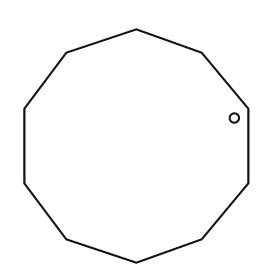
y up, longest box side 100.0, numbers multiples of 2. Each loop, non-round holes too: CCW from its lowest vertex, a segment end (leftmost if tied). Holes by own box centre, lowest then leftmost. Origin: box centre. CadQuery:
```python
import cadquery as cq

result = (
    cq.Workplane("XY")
    .moveTo(0.0, -50.0)
    .lineTo(28.0, -40.0)
    .lineTo(48.0, -16.0)
    .lineTo(48.0, 16.0)
    .lineTo(28.0, 40.0)
    .lineTo(0.0, 50.0)
    .lineTo(-30.0, 40.0)
    .lineTo(-48.0, 16.0)
    .lineTo(-48.0, -16.0)
    .lineTo(-30.0, -40.0)
    .close()
    .moveTo(42.0, 12.0)
    .circle(2.0)
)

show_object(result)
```